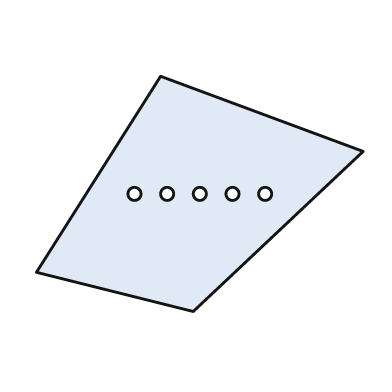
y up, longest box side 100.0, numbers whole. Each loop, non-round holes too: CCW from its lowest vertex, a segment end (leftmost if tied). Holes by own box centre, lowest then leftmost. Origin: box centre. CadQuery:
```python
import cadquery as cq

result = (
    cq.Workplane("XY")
    .moveTo(-2.0, -36.0)
    .lineTo(50.0, 13.0)
    .lineTo(-12.0, 36.0)
    .lineTo(-50.0, -24.0)
    .close()
    .moveTo(-20.0, 0.0)
    .circle(2.0)
    .moveTo(-10.0, 0.0)
    .circle(2.0)
    .moveTo(0.0, 0.0)
    .circle(2.0)
    .moveTo(10.0, 0.0)
    .circle(2.0)
    .moveTo(20.0, 0.0)
    .circle(2.0)
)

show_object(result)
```